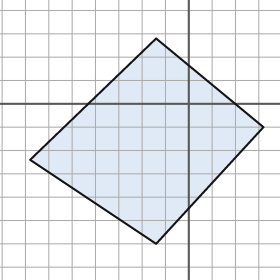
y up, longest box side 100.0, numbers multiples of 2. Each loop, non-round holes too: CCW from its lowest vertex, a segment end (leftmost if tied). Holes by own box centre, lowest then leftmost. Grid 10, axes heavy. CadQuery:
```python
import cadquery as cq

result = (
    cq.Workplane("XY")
    .moveTo(-14.0, -60.0)
    .lineTo(32.0, -10.0)
    .lineTo(-14.0, 28.0)
    .lineTo(-68.0, -24.0)
    .close()
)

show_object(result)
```